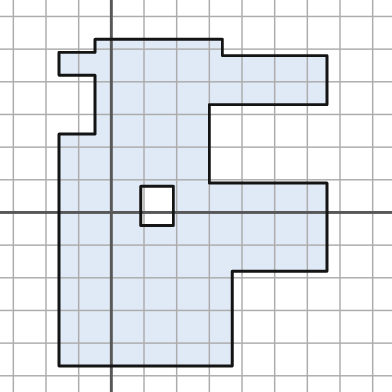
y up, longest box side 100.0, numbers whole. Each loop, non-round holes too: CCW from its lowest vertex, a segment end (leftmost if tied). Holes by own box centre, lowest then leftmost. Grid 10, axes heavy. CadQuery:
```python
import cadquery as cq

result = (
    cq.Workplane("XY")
    .moveTo(-16.0, -47.0)
    .lineTo(37.0, -47.0)
    .lineTo(37.0, -18.0)
    .lineTo(66.0, -18.0)
    .lineTo(66.0, 9.0)
    .lineTo(30.0, 9.0)
    .lineTo(30.0, 33.0)
    .lineTo(66.0, 33.0)
    .lineTo(66.0, 48.0)
    .lineTo(34.0, 48.0)
    .lineTo(34.0, 53.0)
    .lineTo(-5.0, 53.0)
    .lineTo(-5.0, 49.0)
    .lineTo(-16.0, 49.0)
    .lineTo(-16.0, 42.0)
    .lineTo(-5.0, 42.0)
    .lineTo(-5.0, 24.0)
    .lineTo(-16.0, 24.0)
    .close()
    .moveTo(9.0, -4.0)
    .lineTo(19.0, -4.0)
    .lineTo(19.0, 8.0)
    .lineTo(9.0, 8.0)
    .close()
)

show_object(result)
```